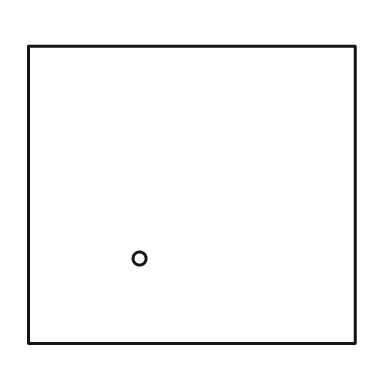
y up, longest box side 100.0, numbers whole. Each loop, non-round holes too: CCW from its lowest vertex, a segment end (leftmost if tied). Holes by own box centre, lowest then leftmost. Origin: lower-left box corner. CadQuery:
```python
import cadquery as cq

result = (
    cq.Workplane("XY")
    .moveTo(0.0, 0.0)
    .lineTo(100.0, 0.0)
    .lineTo(100.0, 91.0)
    .lineTo(0.0, 91.0)
    .close()
    .moveTo(34.0, 26.0)
    .circle(2.0)
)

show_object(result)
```